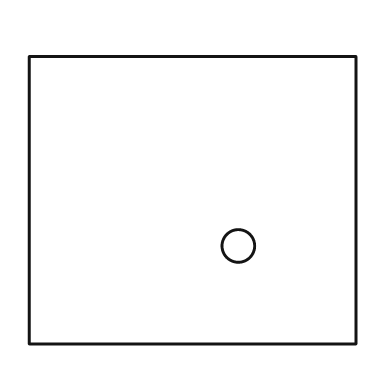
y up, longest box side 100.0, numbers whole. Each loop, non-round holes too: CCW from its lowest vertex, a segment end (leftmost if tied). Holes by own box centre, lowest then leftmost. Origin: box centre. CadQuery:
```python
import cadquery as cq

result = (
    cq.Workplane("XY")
    .moveTo(-50.0, -44.0)
    .lineTo(50.0, -44.0)
    .lineTo(50.0, 44.0)
    .lineTo(-50.0, 44.0)
    .close()
    .moveTo(14.0, -14.0)
    .circle(5.0)
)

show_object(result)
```